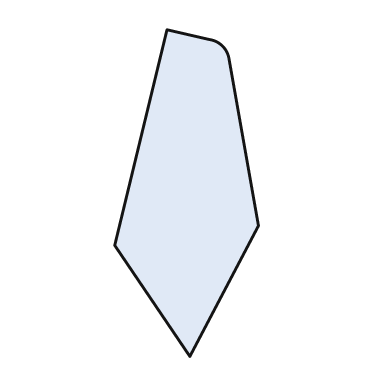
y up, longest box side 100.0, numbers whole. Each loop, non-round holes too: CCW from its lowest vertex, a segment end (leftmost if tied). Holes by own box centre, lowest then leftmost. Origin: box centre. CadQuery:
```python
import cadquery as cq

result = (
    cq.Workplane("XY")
    .moveTo(1.0, -50.0)
    .lineTo(22.0, -10.0)
    .lineTo(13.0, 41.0)
    .threePointArc((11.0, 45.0), (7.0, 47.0))
    .lineTo(-6.0, 50.0)
    .lineTo(-22.0, -16.0)
    .close()
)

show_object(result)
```